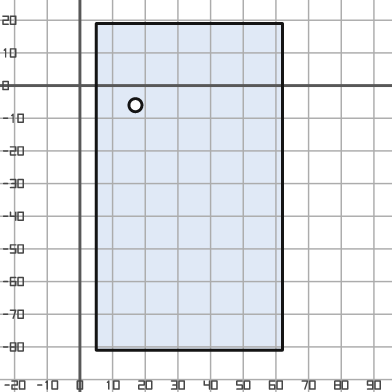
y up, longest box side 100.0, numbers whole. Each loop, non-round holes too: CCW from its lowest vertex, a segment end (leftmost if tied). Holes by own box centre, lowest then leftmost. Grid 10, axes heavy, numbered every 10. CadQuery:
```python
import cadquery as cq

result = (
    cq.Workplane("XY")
    .moveTo(5.0, -81.0)
    .lineTo(62.0, -81.0)
    .lineTo(62.0, 19.0)
    .lineTo(5.0, 19.0)
    .close()
    .moveTo(17.0, -6.0)
    .circle(2.0)
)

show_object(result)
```